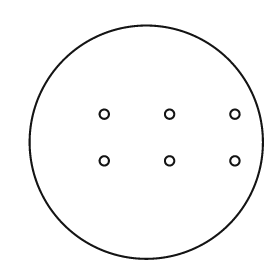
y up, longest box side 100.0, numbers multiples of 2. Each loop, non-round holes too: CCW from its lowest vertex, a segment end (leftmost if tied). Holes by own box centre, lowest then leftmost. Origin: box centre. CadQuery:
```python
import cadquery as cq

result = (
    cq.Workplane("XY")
    .moveTo(0.0, 0.0)
    .circle(50.0)
    .moveTo(-18.0, -8.0)
    .circle(2.0)
    .moveTo(10.0, -8.0)
    .circle(2.0)
    .moveTo(38.0, -8.0)
    .circle(2.0)
    .moveTo(-18.0, 12.0)
    .circle(2.0)
    .moveTo(10.0, 12.0)
    .circle(2.0)
    .moveTo(38.0, 12.0)
    .circle(2.0)
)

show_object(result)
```